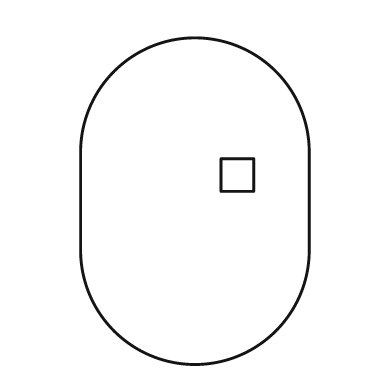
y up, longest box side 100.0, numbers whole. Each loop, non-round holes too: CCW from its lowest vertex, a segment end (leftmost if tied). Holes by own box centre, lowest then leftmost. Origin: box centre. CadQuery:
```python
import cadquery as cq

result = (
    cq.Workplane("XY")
    .moveTo(-35.0, -15.0)
    .threePointArc((0.0, -50.0), (35.0, -15.0))
    .lineTo(35.0, 15.0)
    .threePointArc((0.0, 50.0), (-35.0, 15.0))
    .close()
    .moveTo(8.0, 3.0)
    .lineTo(18.0, 3.0)
    .lineTo(18.0, 13.0)
    .lineTo(8.0, 13.0)
    .close()
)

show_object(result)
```